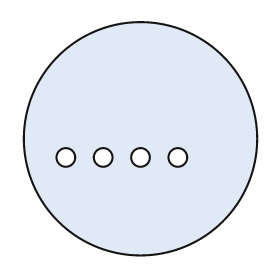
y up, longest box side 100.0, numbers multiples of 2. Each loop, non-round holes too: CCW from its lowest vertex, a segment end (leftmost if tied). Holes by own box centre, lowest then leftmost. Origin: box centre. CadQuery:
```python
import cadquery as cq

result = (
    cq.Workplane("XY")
    .moveTo(0.0, 0.0)
    .circle(50.0)
    .moveTo(-32.0, -8.0)
    .circle(4.0)
    .moveTo(-16.0, -8.0)
    .circle(4.0)
    .moveTo(0.0, -8.0)
    .circle(4.0)
    .moveTo(16.0, -8.0)
    .circle(4.0)
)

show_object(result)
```